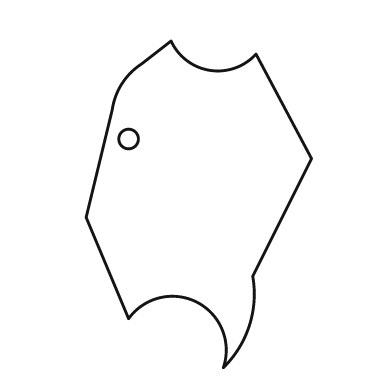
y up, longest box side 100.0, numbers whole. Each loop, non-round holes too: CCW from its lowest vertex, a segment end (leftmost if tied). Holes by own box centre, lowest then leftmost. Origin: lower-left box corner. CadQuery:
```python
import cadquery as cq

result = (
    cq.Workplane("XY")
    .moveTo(42.0, 0.0)
    .threePointArc((50.0, 13.0), (51.0, 28.0))
    .lineTo(69.0, 64.0)
    .lineTo(52.0, 96.0)
    .threePointArc((38.0, 91.0), (26.0, 100.0))
    .lineTo(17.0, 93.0)
    .threePointArc((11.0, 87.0), (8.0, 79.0))
    .lineTo(0.0, 46.0)
    .lineTo(13.0, 15.0)
    .threePointArc((34.0, 20.0), (42.0, 0.0))
    .close()
    .moveTo(13.0, 70.0)
    .circle(3.0)
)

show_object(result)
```